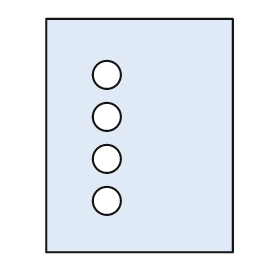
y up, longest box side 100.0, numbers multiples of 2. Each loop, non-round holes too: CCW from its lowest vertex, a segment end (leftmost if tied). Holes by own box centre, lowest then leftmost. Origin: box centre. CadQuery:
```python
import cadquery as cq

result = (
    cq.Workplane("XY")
    .moveTo(-40.0, -50.0)
    .lineTo(40.0, -50.0)
    .lineTo(40.0, 50.0)
    .lineTo(-40.0, 50.0)
    .close()
    .moveTo(-14.0, -28.0)
    .circle(6.0)
    .moveTo(-14.0, -10.0)
    .circle(6.0)
    .moveTo(-14.0, 8.0)
    .circle(6.0)
    .moveTo(-14.0, 26.0)
    .circle(6.0)
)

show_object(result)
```